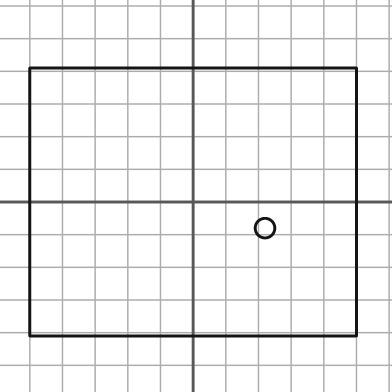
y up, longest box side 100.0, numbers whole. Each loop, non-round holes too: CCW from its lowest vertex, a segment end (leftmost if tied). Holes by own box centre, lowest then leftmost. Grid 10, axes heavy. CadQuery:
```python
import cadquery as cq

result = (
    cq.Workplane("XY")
    .moveTo(-50.0, -41.0)
    .lineTo(50.0, -41.0)
    .lineTo(50.0, 41.0)
    .lineTo(-50.0, 41.0)
    .close()
    .moveTo(22.0, -8.0)
    .circle(3.0)
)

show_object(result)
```